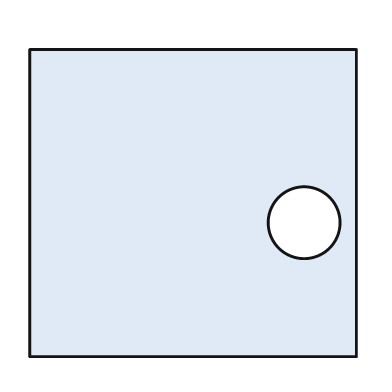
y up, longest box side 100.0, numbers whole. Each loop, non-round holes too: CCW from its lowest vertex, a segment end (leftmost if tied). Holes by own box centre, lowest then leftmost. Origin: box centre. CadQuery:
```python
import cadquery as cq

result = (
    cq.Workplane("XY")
    .moveTo(-50.0, -47.0)
    .lineTo(50.0, -47.0)
    .lineTo(50.0, 47.0)
    .lineTo(-50.0, 47.0)
    .close()
    .moveTo(34.0, -6.0)
    .circle(11.0)
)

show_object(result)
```